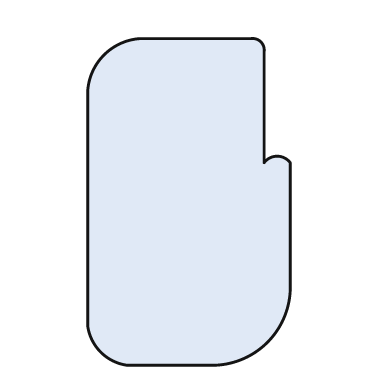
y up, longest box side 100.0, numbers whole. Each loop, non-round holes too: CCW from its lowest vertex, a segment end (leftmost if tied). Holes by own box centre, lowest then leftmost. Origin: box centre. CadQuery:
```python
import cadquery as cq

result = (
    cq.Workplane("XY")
    .moveTo(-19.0, -50.0)
    .lineTo(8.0, -50.0)
    .threePointArc((24.0, -43.0), (31.0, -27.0))
    .lineTo(31.0, 12.0)
    .threePointArc((27.0, 14.0), (23.0, 12.0))
    .lineTo(23.0, 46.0)
    .threePointArc((22.0, 49.0), (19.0, 50.0))
    .lineTo(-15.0, 50.0)
    .threePointArc((-26.0, 45.0), (-31.0, 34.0))
    .lineTo(-31.0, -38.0)
    .threePointArc((-27.0, -46.0), (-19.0, -50.0))
    .close()
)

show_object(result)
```